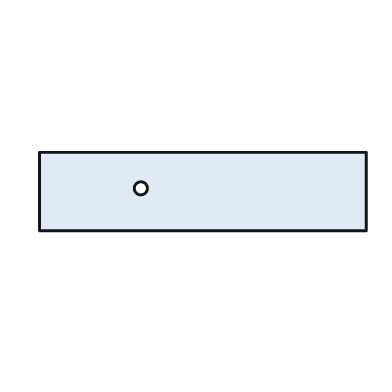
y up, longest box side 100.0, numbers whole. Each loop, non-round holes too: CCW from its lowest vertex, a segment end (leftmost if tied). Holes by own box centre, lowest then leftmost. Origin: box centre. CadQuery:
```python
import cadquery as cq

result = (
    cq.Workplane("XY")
    .moveTo(-50.0, -12.0)
    .lineTo(50.0, -12.0)
    .lineTo(50.0, 12.0)
    .lineTo(-50.0, 12.0)
    .close()
    .moveTo(-19.0, 1.0)
    .circle(2.0)
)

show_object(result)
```